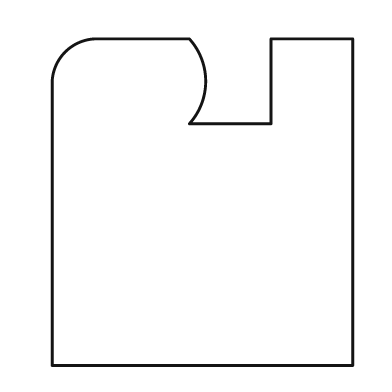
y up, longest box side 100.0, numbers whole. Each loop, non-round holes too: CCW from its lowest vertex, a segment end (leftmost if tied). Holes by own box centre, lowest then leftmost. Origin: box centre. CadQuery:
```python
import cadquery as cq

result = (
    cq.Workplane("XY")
    .moveTo(-46.0, -50.0)
    .lineTo(46.0, -50.0)
    .lineTo(46.0, 50.0)
    .lineTo(21.0, 50.0)
    .lineTo(21.0, 24.0)
    .lineTo(-4.0, 24.0)
    .threePointArc((1.0, 37.0), (-4.0, 50.0))
    .lineTo(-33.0, 50.0)
    .threePointArc((-42.0, 46.0), (-46.0, 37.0))
    .close()
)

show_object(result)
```